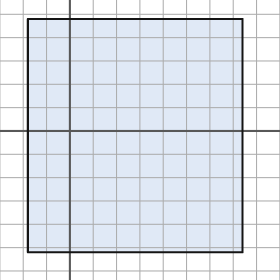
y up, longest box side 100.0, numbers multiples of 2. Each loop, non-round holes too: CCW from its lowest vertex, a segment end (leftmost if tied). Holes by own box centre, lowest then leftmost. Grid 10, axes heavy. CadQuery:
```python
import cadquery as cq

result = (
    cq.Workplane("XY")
    .moveTo(-18.0, -52.0)
    .lineTo(74.0, -52.0)
    .lineTo(74.0, 48.0)
    .lineTo(-18.0, 48.0)
    .close()
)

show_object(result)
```